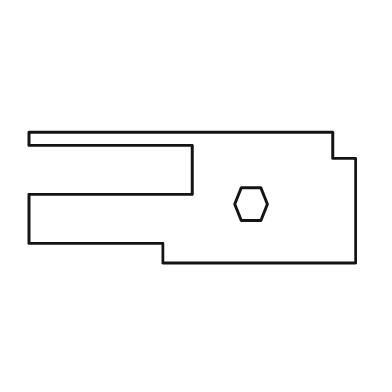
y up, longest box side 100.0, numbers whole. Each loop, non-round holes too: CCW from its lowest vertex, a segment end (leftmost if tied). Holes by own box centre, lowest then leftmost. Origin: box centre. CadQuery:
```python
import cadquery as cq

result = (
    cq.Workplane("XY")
    .moveTo(-9.0, -20.0)
    .lineTo(50.0, -20.0)
    .lineTo(50.0, 12.0)
    .lineTo(43.0, 12.0)
    .lineTo(43.0, 20.0)
    .lineTo(-50.0, 20.0)
    .lineTo(-50.0, 16.0)
    .lineTo(0.0, 16.0)
    .lineTo(0.0, 1.0)
    .lineTo(-50.0, 1.0)
    .lineTo(-50.0, -14.0)
    .lineTo(-9.0, -14.0)
    .close()
    .moveTo(15.0, -7.0)
    .lineTo(21.0, -7.0)
    .lineTo(23.0, -2.0)
    .lineTo(21.0, 3.0)
    .lineTo(15.0, 3.0)
    .lineTo(13.0, -2.0)
    .close()
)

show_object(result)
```